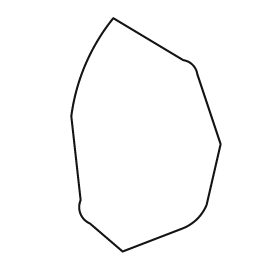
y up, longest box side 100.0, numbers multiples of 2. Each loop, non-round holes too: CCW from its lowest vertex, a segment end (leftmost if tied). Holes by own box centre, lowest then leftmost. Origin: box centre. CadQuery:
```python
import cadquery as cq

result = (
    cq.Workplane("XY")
    .moveTo(-10.0, -50.0)
    .lineTo(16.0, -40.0)
    .threePointArc((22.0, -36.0), (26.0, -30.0))
    .lineTo(32.0, -4.0)
    .lineTo(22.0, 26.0)
    .threePointArc((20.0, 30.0), (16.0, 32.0))
    .lineTo(-14.0, 50.0)
    .threePointArc((-26.0, 30.0), (-32.0, 8.0))
    .lineTo(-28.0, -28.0)
    .threePointArc((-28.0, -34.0), (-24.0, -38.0))
    .close()
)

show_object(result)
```